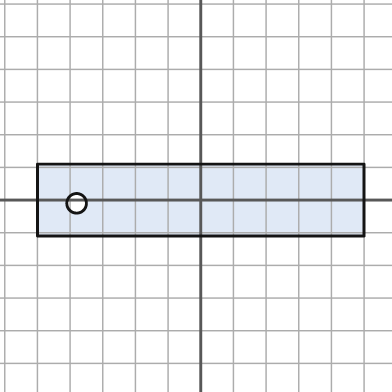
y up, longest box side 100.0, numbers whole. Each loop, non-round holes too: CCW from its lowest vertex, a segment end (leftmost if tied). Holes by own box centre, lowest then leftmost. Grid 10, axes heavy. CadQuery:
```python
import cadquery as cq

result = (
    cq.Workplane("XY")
    .moveTo(-50.0, -11.0)
    .lineTo(50.0, -11.0)
    .lineTo(50.0, 11.0)
    .lineTo(-50.0, 11.0)
    .close()
    .moveTo(-38.0, -1.0)
    .circle(3.0)
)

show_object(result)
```